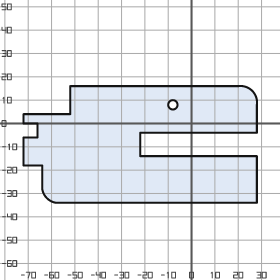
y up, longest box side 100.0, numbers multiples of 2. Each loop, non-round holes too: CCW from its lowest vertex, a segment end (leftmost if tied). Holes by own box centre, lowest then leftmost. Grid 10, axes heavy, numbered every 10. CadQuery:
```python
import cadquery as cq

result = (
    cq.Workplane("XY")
    .moveTo(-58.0, -34.0)
    .lineTo(28.0, -34.0)
    .lineTo(28.0, -14.0)
    .lineTo(-22.0, -14.0)
    .lineTo(-22.0, -4.0)
    .lineTo(28.0, -4.0)
    .lineTo(28.0, 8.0)
    .threePointArc((26.0, 14.0), (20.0, 16.0))
    .lineTo(-52.0, 16.0)
    .lineTo(-52.0, 4.0)
    .lineTo(-72.0, 4.0)
    .lineTo(-72.0, 0.0)
    .lineTo(-66.0, 0.0)
    .lineTo(-66.0, -6.0)
    .lineTo(-72.0, -6.0)
    .lineTo(-72.0, -18.0)
    .lineTo(-64.0, -18.0)
    .lineTo(-64.0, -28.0)
    .threePointArc((-62.0, -32.0), (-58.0, -34.0))
    .close()
    .moveTo(-8.0, 8.0)
    .circle(2.0)
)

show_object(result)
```